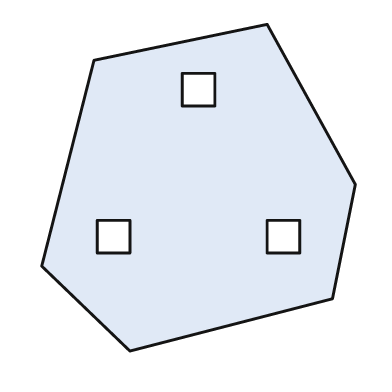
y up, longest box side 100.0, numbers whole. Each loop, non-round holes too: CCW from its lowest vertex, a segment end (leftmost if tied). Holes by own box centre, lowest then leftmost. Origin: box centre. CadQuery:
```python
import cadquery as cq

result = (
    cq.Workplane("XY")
    .moveTo(-21.0, -50.0)
    .lineTo(41.0, -34.0)
    .lineTo(48.0, 1.0)
    .lineTo(21.0, 50.0)
    .lineTo(-32.0, 39.0)
    .lineTo(-48.0, -24.0)
    .close()
    .moveTo(-31.0, -20.0)
    .lineTo(-21.0, -20.0)
    .lineTo(-21.0, -10.0)
    .lineTo(-31.0, -10.0)
    .close()
    .moveTo(21.0, -20.0)
    .lineTo(31.0, -20.0)
    .lineTo(31.0, -10.0)
    .lineTo(21.0, -10.0)
    .close()
    .moveTo(-5.0, 25.0)
    .lineTo(5.0, 25.0)
    .lineTo(5.0, 35.0)
    .lineTo(-5.0, 35.0)
    .close()
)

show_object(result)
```